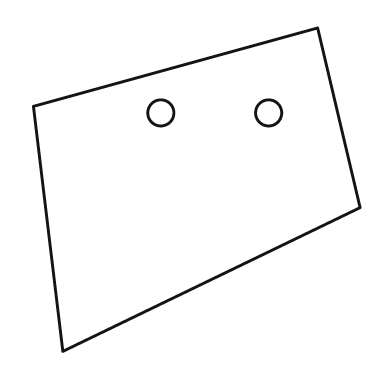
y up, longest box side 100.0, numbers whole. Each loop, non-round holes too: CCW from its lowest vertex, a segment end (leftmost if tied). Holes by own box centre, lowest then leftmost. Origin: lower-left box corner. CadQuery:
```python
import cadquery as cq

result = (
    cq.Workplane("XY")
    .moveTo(9.0, 0.0)
    .lineTo(100.0, 44.0)
    .lineTo(87.0, 99.0)
    .lineTo(0.0, 75.0)
    .close()
    .moveTo(39.0, 73.0)
    .circle(4.0)
    .moveTo(72.0, 73.0)
    .circle(4.0)
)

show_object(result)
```